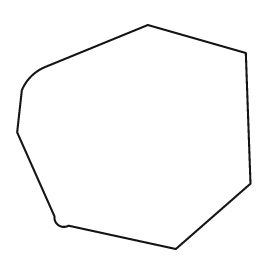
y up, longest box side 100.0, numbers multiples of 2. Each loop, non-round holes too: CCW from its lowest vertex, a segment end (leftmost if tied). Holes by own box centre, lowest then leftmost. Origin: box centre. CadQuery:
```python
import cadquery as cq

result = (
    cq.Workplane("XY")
    .moveTo(18.0, -48.0)
    .lineTo(50.0, -20.0)
    .lineTo(48.0, 36.0)
    .lineTo(6.0, 48.0)
    .lineTo(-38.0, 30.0)
    .threePointArc((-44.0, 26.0), (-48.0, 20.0))
    .lineTo(-50.0, 2.0)
    .lineTo(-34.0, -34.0)
    .threePointArc((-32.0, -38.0), (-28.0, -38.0))
    .close()
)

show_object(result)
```